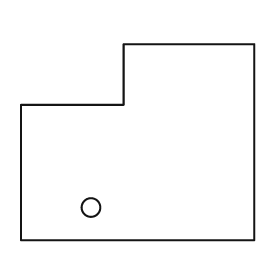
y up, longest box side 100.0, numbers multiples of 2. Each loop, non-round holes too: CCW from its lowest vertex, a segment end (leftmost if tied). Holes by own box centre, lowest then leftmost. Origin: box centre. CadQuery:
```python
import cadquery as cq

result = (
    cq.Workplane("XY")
    .moveTo(-50.0, -42.0)
    .lineTo(50.0, -42.0)
    .lineTo(50.0, 42.0)
    .lineTo(-6.0, 42.0)
    .lineTo(-6.0, 16.0)
    .lineTo(-50.0, 16.0)
    .close()
    .moveTo(-20.0, -28.0)
    .circle(4.0)
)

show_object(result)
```